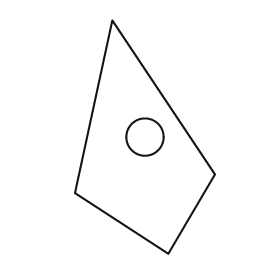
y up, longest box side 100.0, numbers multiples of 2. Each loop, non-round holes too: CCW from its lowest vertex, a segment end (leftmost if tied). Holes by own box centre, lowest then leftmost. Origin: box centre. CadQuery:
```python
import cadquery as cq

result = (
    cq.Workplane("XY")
    .moveTo(10.0, -50.0)
    .lineTo(30.0, -16.0)
    .lineTo(-14.0, 50.0)
    .lineTo(-30.0, -24.0)
    .close()
    .moveTo(0.0, 0.0)
    .circle(8.0)
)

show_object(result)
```